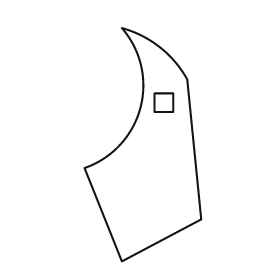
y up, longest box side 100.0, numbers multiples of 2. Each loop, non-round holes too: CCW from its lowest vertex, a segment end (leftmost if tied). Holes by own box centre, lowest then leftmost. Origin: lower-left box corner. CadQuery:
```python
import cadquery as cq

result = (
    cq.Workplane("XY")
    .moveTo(16.0, 0.0)
    .lineTo(50.0, 18.0)
    .lineTo(44.0, 78.0)
    .threePointArc((32.0, 92.0), (16.0, 100.0))
    .threePointArc((24.0, 66.0), (0.0, 40.0))
    .close()
    .moveTo(30.0, 64.0)
    .lineTo(38.0, 64.0)
    .lineTo(38.0, 72.0)
    .lineTo(30.0, 72.0)
    .close()
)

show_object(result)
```